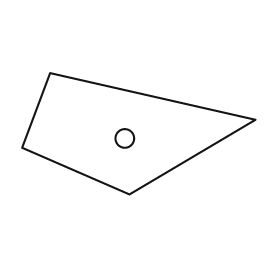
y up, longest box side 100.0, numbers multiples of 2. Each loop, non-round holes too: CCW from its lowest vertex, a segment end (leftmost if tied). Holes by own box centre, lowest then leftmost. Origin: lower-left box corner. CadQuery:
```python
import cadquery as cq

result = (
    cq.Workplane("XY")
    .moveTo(46.0, 0.0)
    .lineTo(100.0, 32.0)
    .lineTo(12.0, 52.0)
    .lineTo(0.0, 20.0)
    .close()
    .moveTo(44.0, 24.0)
    .circle(4.0)
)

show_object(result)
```